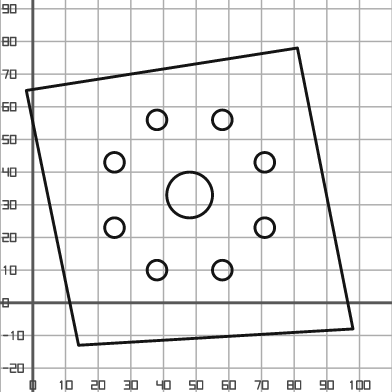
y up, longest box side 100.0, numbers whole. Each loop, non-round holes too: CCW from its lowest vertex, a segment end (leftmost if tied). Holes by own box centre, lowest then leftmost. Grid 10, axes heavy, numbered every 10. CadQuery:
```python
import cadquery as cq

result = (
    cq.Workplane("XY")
    .moveTo(14.0, -13.0)
    .lineTo(98.0, -8.0)
    .lineTo(81.0, 78.0)
    .lineTo(-2.0, 65.0)
    .close()
    .moveTo(38.0, 10.0)
    .circle(3.0)
    .moveTo(58.0, 10.0)
    .circle(3.0)
    .moveTo(25.0, 23.0)
    .circle(3.0)
    .moveTo(71.0, 23.0)
    .circle(3.0)
    .moveTo(48.0, 33.0)
    .circle(7.0)
    .moveTo(25.0, 43.0)
    .circle(3.0)
    .moveTo(71.0, 43.0)
    .circle(3.0)
    .moveTo(38.0, 56.0)
    .circle(3.0)
    .moveTo(58.0, 56.0)
    .circle(3.0)
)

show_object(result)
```